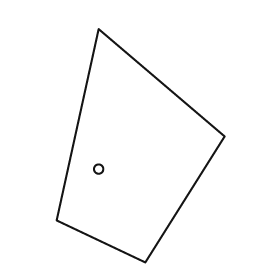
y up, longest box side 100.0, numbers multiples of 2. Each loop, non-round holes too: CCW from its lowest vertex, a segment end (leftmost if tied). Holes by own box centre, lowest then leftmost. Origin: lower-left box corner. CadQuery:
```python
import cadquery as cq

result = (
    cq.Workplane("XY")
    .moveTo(38.0, 0.0)
    .lineTo(72.0, 54.0)
    .lineTo(18.0, 100.0)
    .lineTo(0.0, 18.0)
    .close()
    .moveTo(18.0, 40.0)
    .circle(2.0)
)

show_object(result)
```